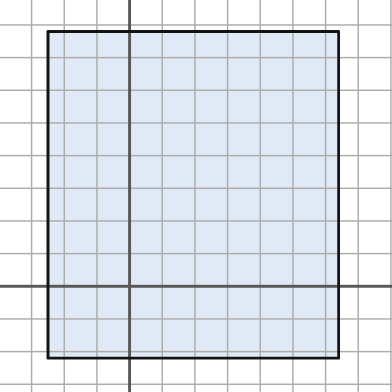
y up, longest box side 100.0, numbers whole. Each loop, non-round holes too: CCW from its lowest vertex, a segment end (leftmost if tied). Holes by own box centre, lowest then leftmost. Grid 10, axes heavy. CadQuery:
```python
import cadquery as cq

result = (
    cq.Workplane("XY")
    .moveTo(-25.0, -22.0)
    .lineTo(64.0, -22.0)
    .lineTo(64.0, 78.0)
    .lineTo(-25.0, 78.0)
    .close()
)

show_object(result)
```